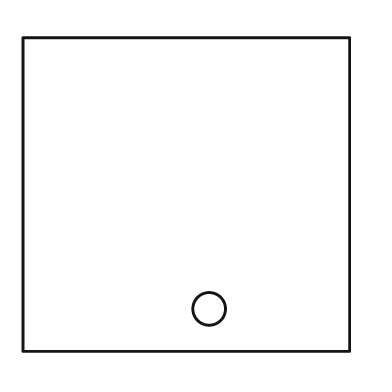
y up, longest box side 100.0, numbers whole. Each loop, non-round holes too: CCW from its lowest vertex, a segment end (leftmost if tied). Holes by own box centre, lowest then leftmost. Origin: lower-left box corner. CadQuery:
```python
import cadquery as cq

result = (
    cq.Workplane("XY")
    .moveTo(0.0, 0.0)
    .lineTo(100.0, 0.0)
    .lineTo(100.0, 96.0)
    .lineTo(0.0, 96.0)
    .close()
    .moveTo(57.0, 13.0)
    .circle(5.0)
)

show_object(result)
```